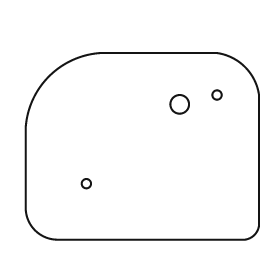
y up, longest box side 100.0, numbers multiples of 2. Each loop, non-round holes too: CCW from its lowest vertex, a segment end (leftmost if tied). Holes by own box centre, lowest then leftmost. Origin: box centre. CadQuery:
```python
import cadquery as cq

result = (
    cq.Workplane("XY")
    .moveTo(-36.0, -40.0)
    .lineTo(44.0, -40.0)
    .threePointArc((48.0, -38.0), (50.0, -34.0))
    .lineTo(50.0, 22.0)
    .threePointArc((44.0, 34.0), (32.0, 40.0))
    .lineTo(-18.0, 40.0)
    .threePointArc((-40.0, 30.0), (-50.0, 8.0))
    .lineTo(-50.0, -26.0)
    .threePointArc((-46.0, -36.0), (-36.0, -40.0))
    .close()
    .moveTo(-24.0, -16.0)
    .circle(2.0)
    .moveTo(16.0, 18.0)
    .circle(4.0)
    .moveTo(32.0, 22.0)
    .circle(2.0)
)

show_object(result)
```